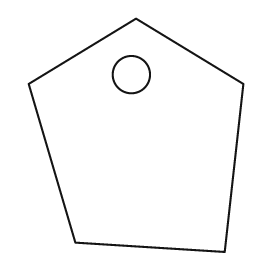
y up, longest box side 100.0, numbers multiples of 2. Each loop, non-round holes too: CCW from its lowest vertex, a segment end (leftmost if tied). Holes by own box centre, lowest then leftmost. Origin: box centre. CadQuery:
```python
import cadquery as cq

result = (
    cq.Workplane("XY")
    .moveTo(38.0, -50.0)
    .lineTo(46.0, 22.0)
    .lineTo(0.0, 50.0)
    .lineTo(-46.0, 22.0)
    .lineTo(-26.0, -46.0)
    .close()
    .moveTo(-2.0, 26.0)
    .circle(8.0)
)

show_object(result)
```